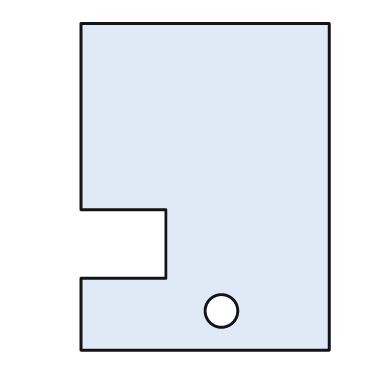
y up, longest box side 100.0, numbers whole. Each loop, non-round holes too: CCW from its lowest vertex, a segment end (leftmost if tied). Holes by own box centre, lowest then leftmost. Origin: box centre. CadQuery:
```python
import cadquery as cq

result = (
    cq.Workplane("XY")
    .moveTo(-38.0, -50.0)
    .lineTo(38.0, -50.0)
    .lineTo(38.0, 50.0)
    .lineTo(-38.0, 50.0)
    .lineTo(-38.0, -7.0)
    .lineTo(-12.0, -7.0)
    .lineTo(-12.0, -28.0)
    .lineTo(-38.0, -28.0)
    .close()
    .moveTo(5.0, -38.0)
    .circle(5.0)
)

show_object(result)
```